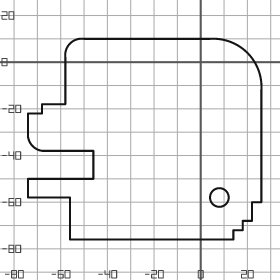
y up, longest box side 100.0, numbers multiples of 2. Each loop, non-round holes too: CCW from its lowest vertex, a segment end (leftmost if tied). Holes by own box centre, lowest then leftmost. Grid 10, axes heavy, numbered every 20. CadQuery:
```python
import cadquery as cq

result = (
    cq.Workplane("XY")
    .moveTo(-56.0, -76.0)
    .lineTo(14.0, -76.0)
    .lineTo(14.0, -72.0)
    .lineTo(18.0, -72.0)
    .lineTo(18.0, -68.0)
    .lineTo(22.0, -68.0)
    .lineTo(22.0, -60.0)
    .lineTo(26.0, -60.0)
    .lineTo(26.0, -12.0)
    .threePointArc((20.0, 4.0), (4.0, 10.0))
    .lineTo(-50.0, 10.0)
    .threePointArc((-56.0, 8.0), (-58.0, 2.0))
    .lineTo(-58.0, -18.0)
    .lineTo(-68.0, -18.0)
    .lineTo(-68.0, -22.0)
    .lineTo(-74.0, -22.0)
    .lineTo(-74.0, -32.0)
    .threePointArc((-72.0, -36.0), (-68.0, -38.0))
    .lineTo(-46.0, -38.0)
    .lineTo(-46.0, -50.0)
    .lineTo(-74.0, -50.0)
    .lineTo(-74.0, -58.0)
    .lineTo(-56.0, -58.0)
    .close()
    .moveTo(8.0, -58.0)
    .circle(4.0)
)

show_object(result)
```